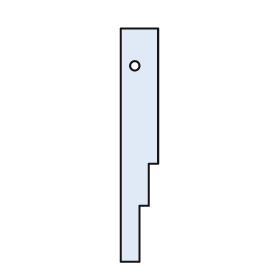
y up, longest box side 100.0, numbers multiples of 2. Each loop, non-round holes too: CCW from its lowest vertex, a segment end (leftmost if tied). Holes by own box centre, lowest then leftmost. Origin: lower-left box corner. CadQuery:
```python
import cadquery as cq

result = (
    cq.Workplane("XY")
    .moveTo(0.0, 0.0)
    .lineTo(8.0, 0.0)
    .lineTo(8.0, 24.0)
    .lineTo(12.0, 24.0)
    .lineTo(12.0, 42.0)
    .lineTo(16.0, 42.0)
    .lineTo(16.0, 100.0)
    .lineTo(0.0, 100.0)
    .close()
    .moveTo(6.0, 84.0)
    .circle(2.0)
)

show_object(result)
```